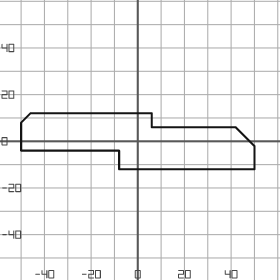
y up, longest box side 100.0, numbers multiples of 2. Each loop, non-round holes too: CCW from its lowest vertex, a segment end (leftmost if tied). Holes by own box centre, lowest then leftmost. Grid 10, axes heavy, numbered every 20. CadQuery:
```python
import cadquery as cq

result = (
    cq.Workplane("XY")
    .moveTo(-8.0, -12.0)
    .lineTo(50.0, -12.0)
    .lineTo(50.0, -2.0)
    .lineTo(42.0, 6.0)
    .lineTo(6.0, 6.0)
    .lineTo(6.0, 12.0)
    .lineTo(-46.0, 12.0)
    .lineTo(-50.0, 8.0)
    .lineTo(-50.0, -4.0)
    .lineTo(-8.0, -4.0)
    .close()
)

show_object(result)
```